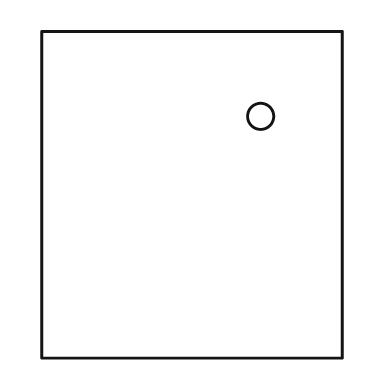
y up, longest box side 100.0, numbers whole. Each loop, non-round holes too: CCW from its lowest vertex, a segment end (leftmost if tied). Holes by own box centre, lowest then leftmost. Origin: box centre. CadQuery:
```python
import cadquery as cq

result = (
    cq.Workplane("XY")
    .moveTo(-46.0, -50.0)
    .lineTo(46.0, -50.0)
    .lineTo(46.0, 50.0)
    .lineTo(-46.0, 50.0)
    .close()
    .moveTo(21.0, 24.0)
    .circle(4.0)
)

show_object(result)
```